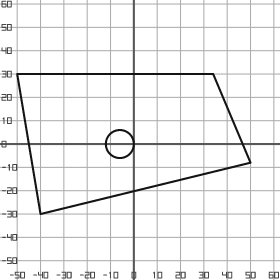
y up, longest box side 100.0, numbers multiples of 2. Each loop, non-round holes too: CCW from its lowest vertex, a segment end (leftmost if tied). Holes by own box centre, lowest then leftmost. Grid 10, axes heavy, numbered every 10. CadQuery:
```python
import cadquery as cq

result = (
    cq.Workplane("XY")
    .moveTo(-40.0, -30.0)
    .lineTo(50.0, -8.0)
    .lineTo(34.0, 30.0)
    .lineTo(-50.0, 30.0)
    .close()
    .moveTo(-6.0, 0.0)
    .circle(6.0)
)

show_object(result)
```